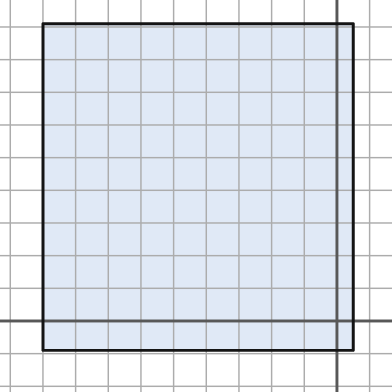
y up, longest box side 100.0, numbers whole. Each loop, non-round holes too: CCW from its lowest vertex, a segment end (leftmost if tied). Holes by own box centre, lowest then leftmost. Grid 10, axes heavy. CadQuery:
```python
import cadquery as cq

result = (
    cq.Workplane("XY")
    .moveTo(-90.0, -9.0)
    .lineTo(5.0, -9.0)
    .lineTo(5.0, 91.0)
    .lineTo(-90.0, 91.0)
    .close()
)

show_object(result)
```